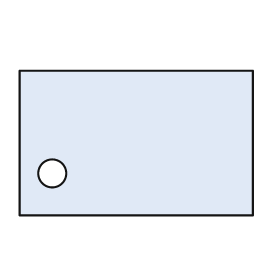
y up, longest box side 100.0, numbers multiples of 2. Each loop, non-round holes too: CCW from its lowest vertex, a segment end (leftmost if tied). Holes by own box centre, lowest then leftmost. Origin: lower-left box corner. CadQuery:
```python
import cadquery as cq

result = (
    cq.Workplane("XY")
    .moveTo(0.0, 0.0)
    .lineTo(100.0, 0.0)
    .lineTo(100.0, 62.0)
    .lineTo(0.0, 62.0)
    .close()
    .moveTo(14.0, 18.0)
    .circle(6.0)
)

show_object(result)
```